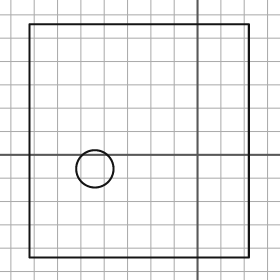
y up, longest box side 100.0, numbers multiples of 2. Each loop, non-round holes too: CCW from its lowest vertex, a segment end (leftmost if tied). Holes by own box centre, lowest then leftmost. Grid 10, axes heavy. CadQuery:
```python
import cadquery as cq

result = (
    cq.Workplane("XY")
    .moveTo(-72.0, -44.0)
    .lineTo(22.0, -44.0)
    .lineTo(22.0, 56.0)
    .lineTo(-72.0, 56.0)
    .close()
    .moveTo(-44.0, -6.0)
    .circle(8.0)
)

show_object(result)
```